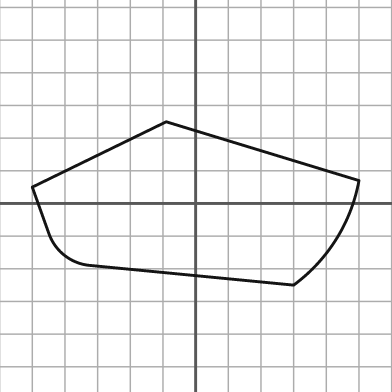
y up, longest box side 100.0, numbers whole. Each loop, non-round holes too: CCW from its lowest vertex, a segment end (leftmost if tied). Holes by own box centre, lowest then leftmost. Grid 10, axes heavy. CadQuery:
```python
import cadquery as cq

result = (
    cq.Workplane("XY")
    .moveTo(30.0, -25.0)
    .threePointArc((43.0, -11.0), (50.0, 7.0))
    .lineTo(-9.0, 25.0)
    .lineTo(-50.0, 5.0)
    .lineTo(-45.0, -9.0)
    .threePointArc((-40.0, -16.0), (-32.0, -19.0))
    .close()
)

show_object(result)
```